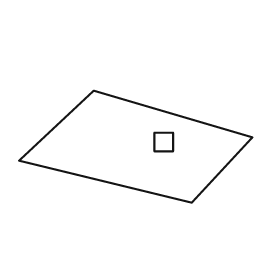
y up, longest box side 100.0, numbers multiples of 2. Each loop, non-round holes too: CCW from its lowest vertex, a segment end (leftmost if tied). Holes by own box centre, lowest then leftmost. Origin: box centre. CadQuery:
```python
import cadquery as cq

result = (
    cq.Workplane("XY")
    .moveTo(24.0, -24.0)
    .lineTo(50.0, 4.0)
    .lineTo(-18.0, 24.0)
    .lineTo(-50.0, -6.0)
    .close()
    .moveTo(8.0, -2.0)
    .lineTo(16.0, -2.0)
    .lineTo(16.0, 6.0)
    .lineTo(8.0, 6.0)
    .close()
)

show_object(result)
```